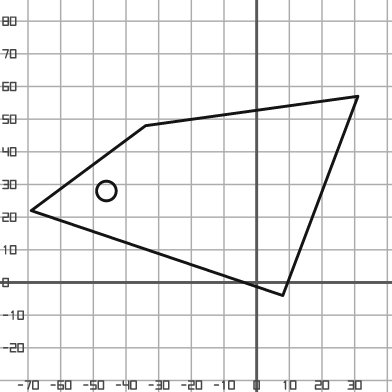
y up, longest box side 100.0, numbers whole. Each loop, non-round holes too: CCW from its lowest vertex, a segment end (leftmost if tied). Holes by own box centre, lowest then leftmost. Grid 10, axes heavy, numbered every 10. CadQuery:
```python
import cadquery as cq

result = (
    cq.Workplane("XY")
    .moveTo(8.0, -4.0)
    .lineTo(31.0, 57.0)
    .lineTo(-34.0, 48.0)
    .lineTo(-69.0, 22.0)
    .close()
    .moveTo(-46.0, 28.0)
    .circle(3.0)
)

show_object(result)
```